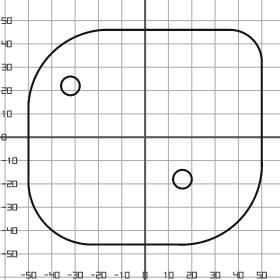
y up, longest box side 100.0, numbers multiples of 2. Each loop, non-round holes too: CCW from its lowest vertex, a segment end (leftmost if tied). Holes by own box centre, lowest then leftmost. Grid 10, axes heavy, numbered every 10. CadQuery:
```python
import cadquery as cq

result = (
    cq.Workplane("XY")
    .moveTo(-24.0, -46.0)
    .lineTo(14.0, -46.0)
    .threePointArc((40.0, -36.0), (50.0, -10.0))
    .lineTo(50.0, 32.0)
    .threePointArc((46.0, 42.0), (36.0, 46.0))
    .lineTo(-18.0, 46.0)
    .threePointArc((-40.0, 36.0), (-50.0, 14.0))
    .lineTo(-50.0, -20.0)
    .threePointArc((-42.0, -38.0), (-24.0, -46.0))
    .close()
    .moveTo(16.0, -18.0)
    .circle(4.0)
    .moveTo(-32.0, 22.0)
    .circle(4.0)
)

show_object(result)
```